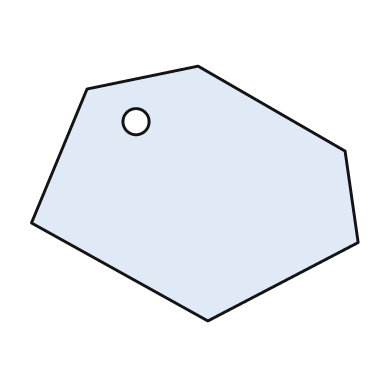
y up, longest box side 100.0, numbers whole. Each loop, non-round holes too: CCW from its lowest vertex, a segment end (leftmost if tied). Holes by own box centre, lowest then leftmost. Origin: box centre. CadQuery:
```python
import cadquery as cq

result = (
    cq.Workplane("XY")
    .moveTo(4.0, -39.0)
    .lineTo(50.0, -15.0)
    .lineTo(46.0, 13.0)
    .lineTo(1.0, 39.0)
    .lineTo(-33.0, 32.0)
    .lineTo(-50.0, -9.0)
    .close()
    .moveTo(-18.0, 22.0)
    .circle(4.0)
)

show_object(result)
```